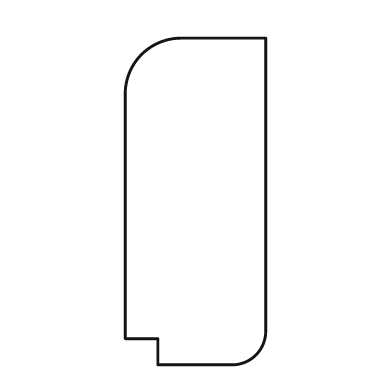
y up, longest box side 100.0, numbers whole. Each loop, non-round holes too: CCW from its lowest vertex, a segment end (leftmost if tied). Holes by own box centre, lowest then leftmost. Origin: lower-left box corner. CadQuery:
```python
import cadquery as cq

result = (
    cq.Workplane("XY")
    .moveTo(10.0, 0.0)
    .lineTo(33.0, 0.0)
    .threePointArc((40.0, 3.0), (43.0, 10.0))
    .lineTo(43.0, 100.0)
    .lineTo(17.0, 100.0)
    .threePointArc((5.0, 95.0), (0.0, 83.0))
    .lineTo(0.0, 8.0)
    .lineTo(10.0, 8.0)
    .close()
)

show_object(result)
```